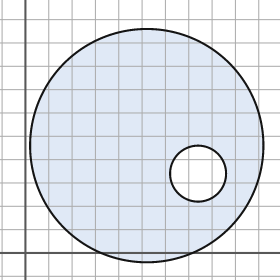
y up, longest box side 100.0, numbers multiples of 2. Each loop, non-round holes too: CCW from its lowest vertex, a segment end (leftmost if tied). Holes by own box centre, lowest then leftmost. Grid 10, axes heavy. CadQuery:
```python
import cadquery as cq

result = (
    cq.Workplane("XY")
    .moveTo(52.0, 46.0)
    .circle(50.0)
    .moveTo(74.0, 34.0)
    .circle(12.0)
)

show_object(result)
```